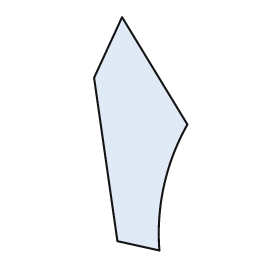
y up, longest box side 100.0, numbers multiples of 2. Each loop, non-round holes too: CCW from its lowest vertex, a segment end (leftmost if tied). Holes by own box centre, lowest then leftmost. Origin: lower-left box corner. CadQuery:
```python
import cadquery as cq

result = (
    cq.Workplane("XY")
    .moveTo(28.0, 0.0)
    .threePointArc((30.0, 28.0), (40.0, 54.0))
    .lineTo(12.0, 100.0)
    .lineTo(0.0, 74.0)
    .lineTo(10.0, 4.0)
    .close()
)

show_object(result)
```